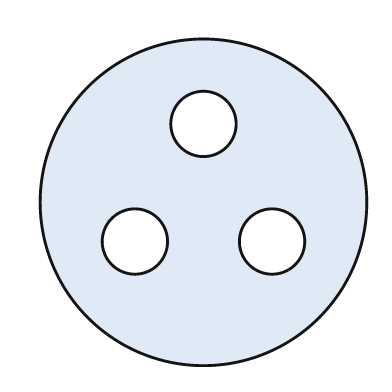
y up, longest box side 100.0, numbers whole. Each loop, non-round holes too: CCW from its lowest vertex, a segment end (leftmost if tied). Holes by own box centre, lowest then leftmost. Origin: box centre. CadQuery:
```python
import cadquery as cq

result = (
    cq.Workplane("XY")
    .moveTo(0.0, 0.0)
    .circle(50.0)
    .moveTo(-21.0, -12.0)
    .circle(10.0)
    .moveTo(21.0, -12.0)
    .circle(10.0)
    .moveTo(0.0, 24.0)
    .circle(10.0)
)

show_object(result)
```